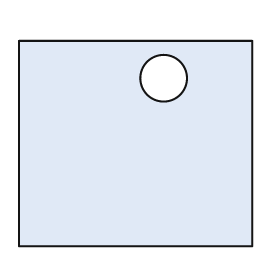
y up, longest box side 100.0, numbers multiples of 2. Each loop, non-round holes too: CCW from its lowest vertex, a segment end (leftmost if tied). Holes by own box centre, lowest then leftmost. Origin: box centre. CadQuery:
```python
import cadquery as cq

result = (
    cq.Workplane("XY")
    .moveTo(-50.0, -44.0)
    .lineTo(50.0, -44.0)
    .lineTo(50.0, 44.0)
    .lineTo(-50.0, 44.0)
    .close()
    .moveTo(12.0, 28.0)
    .circle(10.0)
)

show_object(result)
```